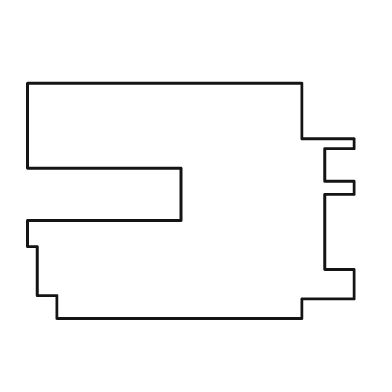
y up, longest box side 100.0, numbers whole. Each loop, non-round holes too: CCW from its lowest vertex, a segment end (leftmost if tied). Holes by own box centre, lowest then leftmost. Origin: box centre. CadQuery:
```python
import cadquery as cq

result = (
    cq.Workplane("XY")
    .moveTo(-41.0, -36.0)
    .lineTo(34.0, -36.0)
    .lineTo(34.0, -30.0)
    .lineTo(50.0, -30.0)
    .lineTo(50.0, -21.0)
    .lineTo(41.0, -21.0)
    .lineTo(41.0, 2.0)
    .lineTo(50.0, 2.0)
    .lineTo(50.0, 6.0)
    .lineTo(41.0, 6.0)
    .lineTo(41.0, 16.0)
    .lineTo(50.0, 16.0)
    .lineTo(50.0, 19.0)
    .lineTo(34.0, 19.0)
    .lineTo(34.0, 36.0)
    .lineTo(-50.0, 36.0)
    .lineTo(-50.0, 10.0)
    .lineTo(-3.0, 10.0)
    .lineTo(-3.0, -6.0)
    .lineTo(-50.0, -6.0)
    .lineTo(-50.0, -14.0)
    .lineTo(-47.0, -14.0)
    .lineTo(-47.0, -29.0)
    .lineTo(-41.0, -29.0)
    .close()
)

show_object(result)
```